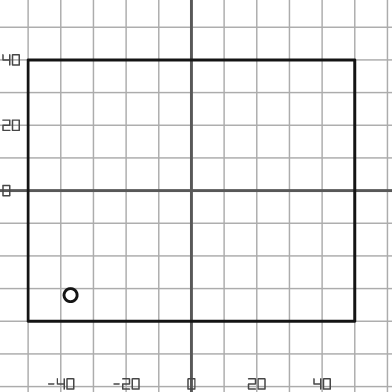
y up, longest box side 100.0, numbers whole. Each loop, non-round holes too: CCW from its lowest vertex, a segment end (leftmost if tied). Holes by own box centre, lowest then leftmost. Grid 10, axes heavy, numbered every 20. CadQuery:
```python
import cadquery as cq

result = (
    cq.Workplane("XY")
    .moveTo(-50.0, -40.0)
    .lineTo(50.0, -40.0)
    .lineTo(50.0, 40.0)
    .lineTo(-50.0, 40.0)
    .close()
    .moveTo(-37.0, -32.0)
    .circle(2.0)
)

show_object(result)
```